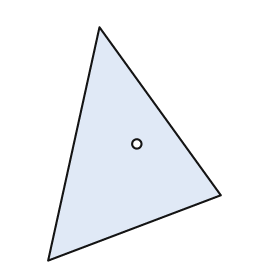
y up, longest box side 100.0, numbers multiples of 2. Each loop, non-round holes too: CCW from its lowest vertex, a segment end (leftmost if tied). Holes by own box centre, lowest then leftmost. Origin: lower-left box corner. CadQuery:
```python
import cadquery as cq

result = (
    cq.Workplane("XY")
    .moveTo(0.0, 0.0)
    .lineTo(74.0, 28.0)
    .lineTo(22.0, 100.0)
    .close()
    .moveTo(38.0, 50.0)
    .circle(2.0)
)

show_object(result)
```